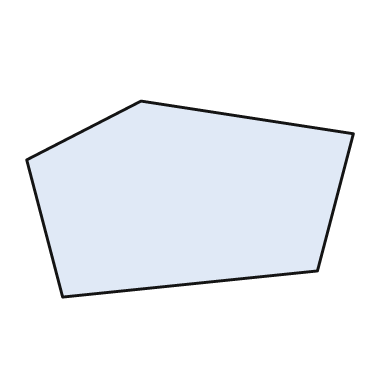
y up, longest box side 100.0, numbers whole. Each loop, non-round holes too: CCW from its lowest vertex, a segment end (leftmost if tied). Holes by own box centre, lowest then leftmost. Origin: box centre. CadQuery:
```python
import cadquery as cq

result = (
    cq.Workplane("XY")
    .moveTo(-39.0, -30.0)
    .lineTo(39.0, -22.0)
    .lineTo(50.0, 20.0)
    .lineTo(-15.0, 30.0)
    .lineTo(-50.0, 12.0)
    .close()
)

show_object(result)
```